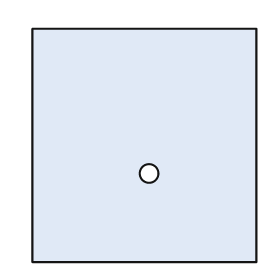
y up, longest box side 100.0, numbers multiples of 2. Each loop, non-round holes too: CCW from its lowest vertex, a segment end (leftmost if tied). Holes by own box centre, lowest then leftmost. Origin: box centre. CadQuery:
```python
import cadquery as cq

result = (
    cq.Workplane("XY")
    .moveTo(-48.0, -50.0)
    .lineTo(48.0, -50.0)
    .lineTo(48.0, 50.0)
    .lineTo(-48.0, 50.0)
    .close()
    .moveTo(2.0, -12.0)
    .circle(4.0)
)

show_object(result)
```